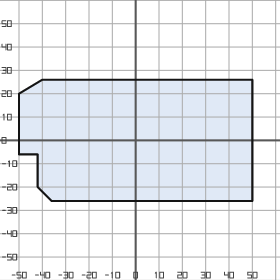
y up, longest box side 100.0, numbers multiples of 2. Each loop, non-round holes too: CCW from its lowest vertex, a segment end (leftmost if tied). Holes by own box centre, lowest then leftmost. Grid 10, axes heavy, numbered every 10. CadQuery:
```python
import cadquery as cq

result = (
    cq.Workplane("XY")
    .moveTo(-36.0, -26.0)
    .lineTo(50.0, -26.0)
    .lineTo(50.0, 26.0)
    .lineTo(-40.0, 26.0)
    .lineTo(-50.0, 20.0)
    .lineTo(-50.0, -6.0)
    .lineTo(-42.0, -6.0)
    .lineTo(-42.0, -20.0)
    .close()
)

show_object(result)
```